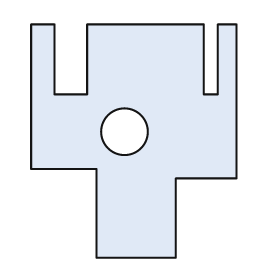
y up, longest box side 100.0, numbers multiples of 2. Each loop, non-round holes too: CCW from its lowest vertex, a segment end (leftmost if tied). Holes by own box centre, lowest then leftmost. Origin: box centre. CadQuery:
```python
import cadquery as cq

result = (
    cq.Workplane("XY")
    .moveTo(-16.0, -50.0)
    .lineTo(18.0, -50.0)
    .lineTo(18.0, -16.0)
    .lineTo(44.0, -16.0)
    .lineTo(44.0, 50.0)
    .lineTo(36.0, 50.0)
    .lineTo(36.0, 20.0)
    .lineTo(30.0, 20.0)
    .lineTo(30.0, 50.0)
    .lineTo(-20.0, 50.0)
    .lineTo(-20.0, 20.0)
    .lineTo(-34.0, 20.0)
    .lineTo(-34.0, 50.0)
    .lineTo(-44.0, 50.0)
    .lineTo(-44.0, -12.0)
    .lineTo(-16.0, -12.0)
    .close()
    .moveTo(-4.0, 4.0)
    .circle(10.0)
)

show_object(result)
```